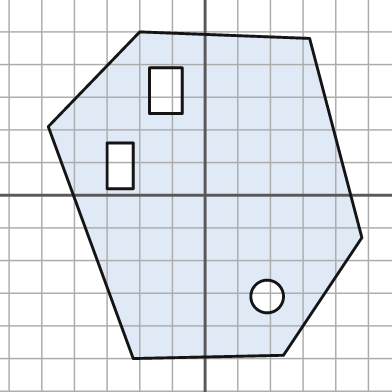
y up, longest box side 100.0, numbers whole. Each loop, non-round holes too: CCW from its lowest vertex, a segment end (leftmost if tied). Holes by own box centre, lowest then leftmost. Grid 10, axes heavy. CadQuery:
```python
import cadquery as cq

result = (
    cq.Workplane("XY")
    .moveTo(-22.0, -50.0)
    .lineTo(24.0, -49.0)
    .lineTo(48.0, -13.0)
    .lineTo(32.0, 48.0)
    .lineTo(-20.0, 50.0)
    .lineTo(-48.0, 21.0)
    .close()
    .moveTo(19.0, -31.0)
    .circle(5.0)
    .moveTo(-30.0, 2.0)
    .lineTo(-22.0, 2.0)
    .lineTo(-22.0, 16.0)
    .lineTo(-30.0, 16.0)
    .close()
    .moveTo(-17.0, 25.0)
    .lineTo(-7.0, 25.0)
    .lineTo(-7.0, 39.0)
    .lineTo(-17.0, 39.0)
    .close()
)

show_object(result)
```